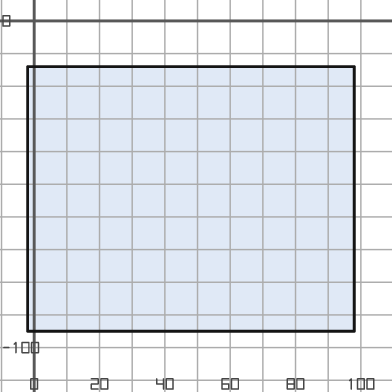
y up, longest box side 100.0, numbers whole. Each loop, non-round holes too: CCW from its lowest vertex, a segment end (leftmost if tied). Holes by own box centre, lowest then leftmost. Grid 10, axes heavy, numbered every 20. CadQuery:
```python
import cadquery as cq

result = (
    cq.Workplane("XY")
    .moveTo(-2.0, -95.0)
    .lineTo(98.0, -95.0)
    .lineTo(98.0, -14.0)
    .lineTo(-2.0, -14.0)
    .close()
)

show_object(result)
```